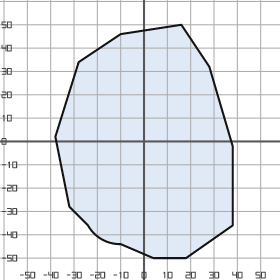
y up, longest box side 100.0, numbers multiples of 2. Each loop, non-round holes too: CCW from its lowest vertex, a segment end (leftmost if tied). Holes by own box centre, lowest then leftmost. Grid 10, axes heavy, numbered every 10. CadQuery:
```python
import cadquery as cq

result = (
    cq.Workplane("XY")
    .moveTo(4.0, -50.0)
    .lineTo(18.0, -50.0)
    .lineTo(38.0, -36.0)
    .lineTo(38.0, -2.0)
    .lineTo(28.0, 32.0)
    .lineTo(16.0, 50.0)
    .lineTo(-10.0, 46.0)
    .lineTo(-28.0, 34.0)
    .lineTo(-38.0, 2.0)
    .lineTo(-32.0, -28.0)
    .lineTo(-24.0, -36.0)
    .threePointArc((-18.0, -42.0), (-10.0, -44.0))
    .close()
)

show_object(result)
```